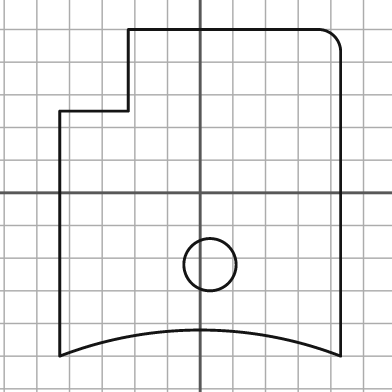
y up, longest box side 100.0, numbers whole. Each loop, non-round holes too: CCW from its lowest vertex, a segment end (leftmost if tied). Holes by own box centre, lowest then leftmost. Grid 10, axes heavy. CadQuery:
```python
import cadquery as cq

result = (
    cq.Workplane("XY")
    .moveTo(-43.0, -50.0)
    .threePointArc((0.0, -42.0), (43.0, -50.0))
    .lineTo(43.0, 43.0)
    .threePointArc((41.0, 48.0), (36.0, 50.0))
    .lineTo(-22.0, 50.0)
    .lineTo(-22.0, 25.0)
    .lineTo(-43.0, 25.0)
    .close()
    .moveTo(3.0, -22.0)
    .circle(8.0)
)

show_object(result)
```